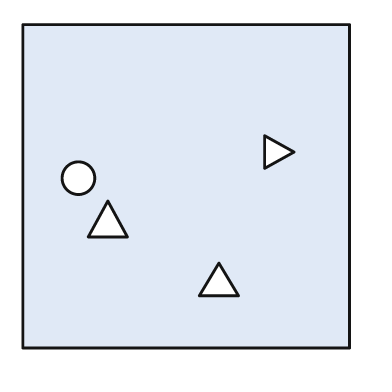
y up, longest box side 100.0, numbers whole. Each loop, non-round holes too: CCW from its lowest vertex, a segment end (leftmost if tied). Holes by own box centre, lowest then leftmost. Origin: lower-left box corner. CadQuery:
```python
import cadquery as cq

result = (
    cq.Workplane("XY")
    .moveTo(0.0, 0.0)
    .lineTo(100.0, 0.0)
    .lineTo(100.0, 99.0)
    .lineTo(0.0, 99.0)
    .close()
    .moveTo(54.0, 16.0)
    .lineTo(66.0, 16.0)
    .lineTo(60.0, 26.0)
    .close()
    .moveTo(20.0, 34.0)
    .lineTo(32.0, 34.0)
    .lineTo(26.0, 45.0)
    .close()
    .moveTo(17.0, 52.0)
    .circle(5.0)
    .moveTo(74.0, 55.0)
    .lineTo(83.0, 60.0)
    .lineTo(74.0, 65.0)
    .close()
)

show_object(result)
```